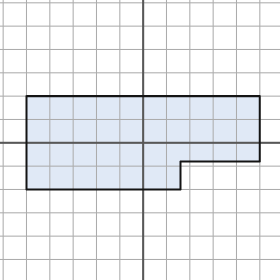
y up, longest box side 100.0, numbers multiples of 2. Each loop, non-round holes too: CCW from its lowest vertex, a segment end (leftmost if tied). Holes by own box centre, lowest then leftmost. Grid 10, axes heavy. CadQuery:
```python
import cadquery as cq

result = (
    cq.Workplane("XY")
    .moveTo(-50.0, -20.0)
    .lineTo(16.0, -20.0)
    .lineTo(16.0, -8.0)
    .lineTo(50.0, -8.0)
    .lineTo(50.0, 20.0)
    .lineTo(-50.0, 20.0)
    .close()
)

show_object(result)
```